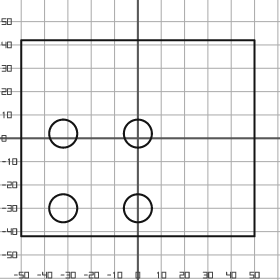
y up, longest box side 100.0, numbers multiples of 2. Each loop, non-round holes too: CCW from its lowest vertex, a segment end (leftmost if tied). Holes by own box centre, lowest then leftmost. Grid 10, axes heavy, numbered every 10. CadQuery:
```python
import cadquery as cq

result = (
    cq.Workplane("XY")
    .moveTo(-50.0, -42.0)
    .lineTo(50.0, -42.0)
    .lineTo(50.0, 42.0)
    .lineTo(-50.0, 42.0)
    .close()
    .moveTo(-32.0, -30.0)
    .circle(6.0)
    .moveTo(0.0, -30.0)
    .circle(6.0)
    .moveTo(-32.0, 2.0)
    .circle(6.0)
    .moveTo(0.0, 2.0)
    .circle(6.0)
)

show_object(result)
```